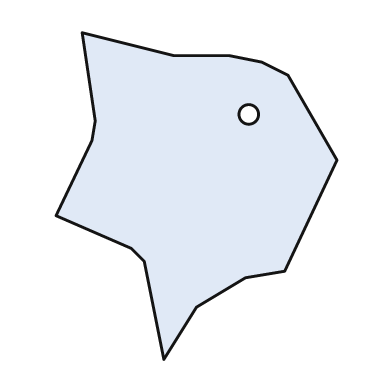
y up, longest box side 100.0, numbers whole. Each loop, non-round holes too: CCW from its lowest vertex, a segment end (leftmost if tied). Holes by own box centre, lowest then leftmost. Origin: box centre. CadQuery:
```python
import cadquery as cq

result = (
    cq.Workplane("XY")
    .moveTo(-10.0, -50.0)
    .lineTo(0.0, -34.0)
    .lineTo(15.0, -25.0)
    .lineTo(27.0, -23.0)
    .lineTo(43.0, 11.0)
    .lineTo(28.0, 37.0)
    .lineTo(20.0, 41.0)
    .lineTo(10.0, 43.0)
    .lineTo(-7.0, 43.0)
    .lineTo(-35.0, 50.0)
    .lineTo(-31.0, 23.0)
    .lineTo(-32.0, 17.0)
    .lineTo(-43.0, -6.0)
    .lineTo(-20.0, -16.0)
    .lineTo(-16.0, -20.0)
    .close()
    .moveTo(16.0, 25.0)
    .circle(3.0)
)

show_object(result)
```